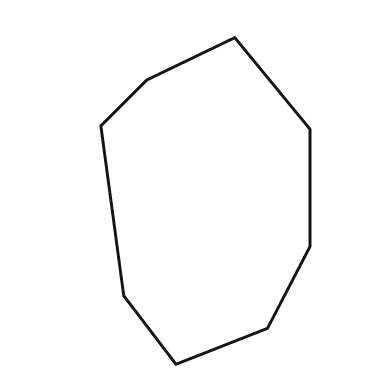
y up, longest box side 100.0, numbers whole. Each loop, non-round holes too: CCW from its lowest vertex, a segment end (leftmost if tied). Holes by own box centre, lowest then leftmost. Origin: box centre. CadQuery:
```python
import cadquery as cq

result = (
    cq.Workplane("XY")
    .moveTo(-9.0, -50.0)
    .lineTo(19.0, -39.0)
    .lineTo(32.0, -14.0)
    .lineTo(32.0, 22.0)
    .lineTo(9.0, 50.0)
    .lineTo(-18.0, 37.0)
    .lineTo(-32.0, 23.0)
    .lineTo(-25.0, -29.0)
    .close()
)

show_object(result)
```